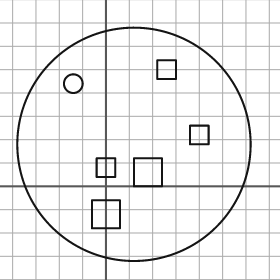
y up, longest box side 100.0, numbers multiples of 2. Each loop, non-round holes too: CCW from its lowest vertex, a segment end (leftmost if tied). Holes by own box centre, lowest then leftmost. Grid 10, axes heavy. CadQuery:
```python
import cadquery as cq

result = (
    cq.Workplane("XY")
    .moveTo(12.0, 18.0)
    .circle(50.0)
    .moveTo(-6.0, -18.0)
    .lineTo(6.0, -18.0)
    .lineTo(6.0, -6.0)
    .lineTo(-6.0, -6.0)
    .close()
    .moveTo(12.0, 0.0)
    .lineTo(24.0, 0.0)
    .lineTo(24.0, 12.0)
    .lineTo(12.0, 12.0)
    .close()
    .moveTo(-4.0, 4.0)
    .lineTo(4.0, 4.0)
    .lineTo(4.0, 12.0)
    .lineTo(-4.0, 12.0)
    .close()
    .moveTo(36.0, 18.0)
    .lineTo(44.0, 18.0)
    .lineTo(44.0, 26.0)
    .lineTo(36.0, 26.0)
    .close()
    .moveTo(-14.0, 44.0)
    .circle(4.0)
    .moveTo(22.0, 46.0)
    .lineTo(30.0, 46.0)
    .lineTo(30.0, 54.0)
    .lineTo(22.0, 54.0)
    .close()
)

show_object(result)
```